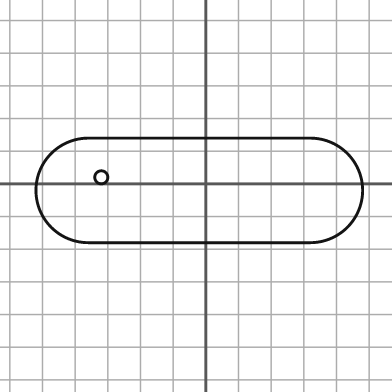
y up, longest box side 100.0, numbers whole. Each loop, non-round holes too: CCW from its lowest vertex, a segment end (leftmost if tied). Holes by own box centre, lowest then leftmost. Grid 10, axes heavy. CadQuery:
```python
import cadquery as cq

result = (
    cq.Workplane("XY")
    .moveTo(-36.0, -18.0)
    .lineTo(32.0, -18.0)
    .threePointArc((48.0, -2.0), (32.0, 14.0))
    .lineTo(-36.0, 14.0)
    .threePointArc((-52.0, -2.0), (-36.0, -18.0))
    .close()
    .moveTo(-32.0, 2.0)
    .circle(2.0)
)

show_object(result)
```